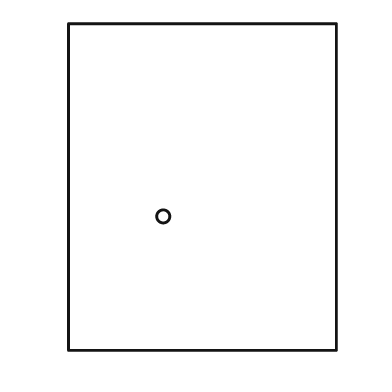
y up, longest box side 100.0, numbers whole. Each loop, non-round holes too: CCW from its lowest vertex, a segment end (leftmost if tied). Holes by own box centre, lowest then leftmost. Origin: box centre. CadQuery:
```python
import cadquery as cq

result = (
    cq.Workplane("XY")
    .moveTo(-41.0, -50.0)
    .lineTo(41.0, -50.0)
    .lineTo(41.0, 50.0)
    .lineTo(-41.0, 50.0)
    .close()
    .moveTo(-12.0, -9.0)
    .circle(2.0)
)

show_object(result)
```